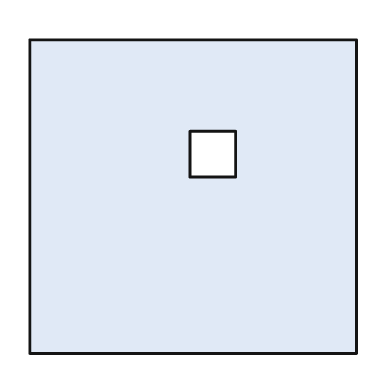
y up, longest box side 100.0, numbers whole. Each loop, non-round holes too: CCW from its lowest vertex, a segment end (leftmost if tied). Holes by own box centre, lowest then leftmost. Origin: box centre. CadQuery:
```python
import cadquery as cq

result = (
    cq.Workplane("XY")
    .moveTo(-50.0, -48.0)
    .lineTo(50.0, -48.0)
    .lineTo(50.0, 48.0)
    .lineTo(-50.0, 48.0)
    .close()
    .moveTo(-1.0, 6.0)
    .lineTo(13.0, 6.0)
    .lineTo(13.0, 20.0)
    .lineTo(-1.0, 20.0)
    .close()
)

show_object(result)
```